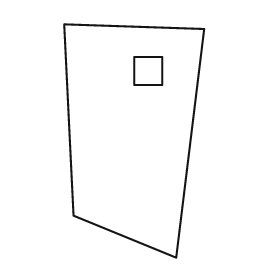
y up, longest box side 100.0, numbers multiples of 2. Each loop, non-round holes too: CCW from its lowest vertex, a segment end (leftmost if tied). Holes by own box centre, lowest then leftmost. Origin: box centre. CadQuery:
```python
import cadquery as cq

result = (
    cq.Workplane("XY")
    .moveTo(18.0, -50.0)
    .lineTo(30.0, 48.0)
    .lineTo(-30.0, 50.0)
    .lineTo(-26.0, -32.0)
    .close()
    .moveTo(0.0, 24.0)
    .lineTo(12.0, 24.0)
    .lineTo(12.0, 36.0)
    .lineTo(0.0, 36.0)
    .close()
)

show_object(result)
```